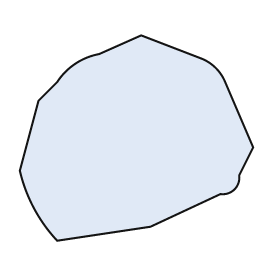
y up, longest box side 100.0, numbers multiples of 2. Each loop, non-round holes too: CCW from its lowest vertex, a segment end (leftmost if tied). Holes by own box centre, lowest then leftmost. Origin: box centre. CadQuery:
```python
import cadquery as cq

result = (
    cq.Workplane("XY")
    .moveTo(-34.0, -44.0)
    .lineTo(6.0, -38.0)
    .lineTo(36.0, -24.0)
    .threePointArc((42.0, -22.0), (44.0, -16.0))
    .lineTo(50.0, -4.0)
    .lineTo(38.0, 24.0)
    .threePointArc((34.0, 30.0), (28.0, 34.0))
    .lineTo(2.0, 44.0)
    .lineTo(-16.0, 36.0)
    .threePointArc((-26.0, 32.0), (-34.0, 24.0))
    .lineTo(-42.0, 16.0)
    .lineTo(-50.0, -14.0)
    .threePointArc((-44.0, -30.0), (-34.0, -44.0))
    .close()
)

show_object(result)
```